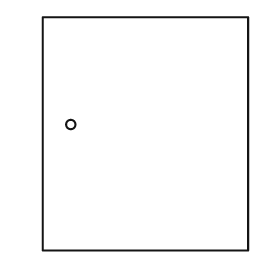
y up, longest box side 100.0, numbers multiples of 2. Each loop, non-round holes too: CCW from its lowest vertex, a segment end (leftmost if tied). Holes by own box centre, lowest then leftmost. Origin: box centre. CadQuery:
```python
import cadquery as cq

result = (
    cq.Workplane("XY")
    .moveTo(-44.0, -50.0)
    .lineTo(44.0, -50.0)
    .lineTo(44.0, 50.0)
    .lineTo(-44.0, 50.0)
    .close()
    .moveTo(-32.0, 4.0)
    .circle(2.0)
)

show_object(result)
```